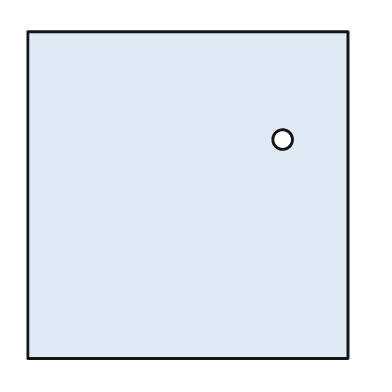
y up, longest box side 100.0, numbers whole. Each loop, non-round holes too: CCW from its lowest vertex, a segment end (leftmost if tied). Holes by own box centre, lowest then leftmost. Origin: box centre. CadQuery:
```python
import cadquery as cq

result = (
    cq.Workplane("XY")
    .moveTo(-49.0, -50.0)
    .lineTo(49.0, -50.0)
    .lineTo(49.0, 50.0)
    .lineTo(-49.0, 50.0)
    .close()
    .moveTo(29.0, 17.0)
    .circle(3.0)
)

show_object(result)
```